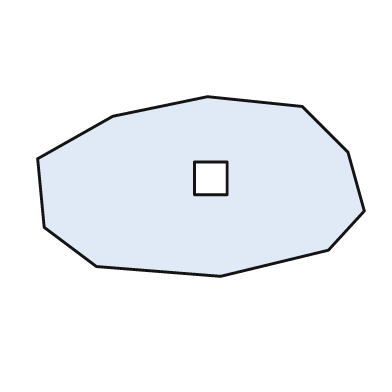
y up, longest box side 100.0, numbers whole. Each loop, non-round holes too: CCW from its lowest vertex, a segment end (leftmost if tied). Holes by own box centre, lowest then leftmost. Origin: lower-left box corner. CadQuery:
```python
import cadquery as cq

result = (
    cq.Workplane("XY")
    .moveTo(56.0, 0.0)
    .lineTo(89.0, 8.0)
    .lineTo(100.0, 20.0)
    .lineTo(95.0, 38.0)
    .lineTo(81.0, 52.0)
    .lineTo(52.0, 55.0)
    .lineTo(23.0, 49.0)
    .lineTo(0.0, 36.0)
    .lineTo(2.0, 15.0)
    .lineTo(18.0, 3.0)
    .close()
    .moveTo(48.0, 25.0)
    .lineTo(58.0, 25.0)
    .lineTo(58.0, 35.0)
    .lineTo(48.0, 35.0)
    .close()
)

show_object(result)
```